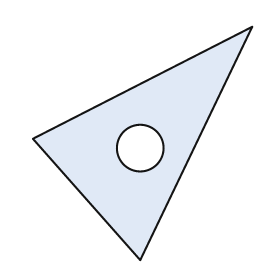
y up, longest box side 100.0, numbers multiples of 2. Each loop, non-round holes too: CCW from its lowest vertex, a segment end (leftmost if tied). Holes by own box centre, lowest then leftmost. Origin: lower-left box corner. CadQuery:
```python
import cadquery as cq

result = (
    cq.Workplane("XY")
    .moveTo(46.0, 0.0)
    .lineTo(94.0, 100.0)
    .lineTo(0.0, 52.0)
    .close()
    .moveTo(46.0, 48.0)
    .circle(10.0)
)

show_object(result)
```